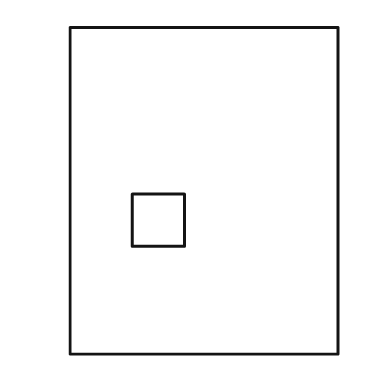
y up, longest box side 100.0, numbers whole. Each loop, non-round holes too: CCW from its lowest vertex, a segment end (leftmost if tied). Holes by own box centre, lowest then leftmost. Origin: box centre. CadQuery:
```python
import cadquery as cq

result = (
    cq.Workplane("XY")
    .moveTo(-41.0, -50.0)
    .lineTo(41.0, -50.0)
    .lineTo(41.0, 50.0)
    .lineTo(-41.0, 50.0)
    .close()
    .moveTo(-22.0, -17.0)
    .lineTo(-6.0, -17.0)
    .lineTo(-6.0, -1.0)
    .lineTo(-22.0, -1.0)
    .close()
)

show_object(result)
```